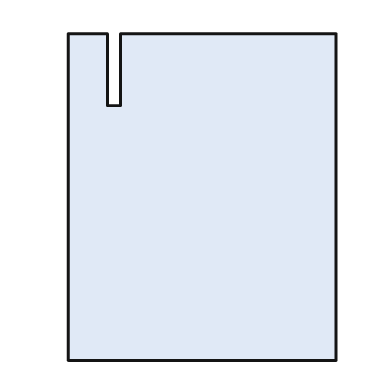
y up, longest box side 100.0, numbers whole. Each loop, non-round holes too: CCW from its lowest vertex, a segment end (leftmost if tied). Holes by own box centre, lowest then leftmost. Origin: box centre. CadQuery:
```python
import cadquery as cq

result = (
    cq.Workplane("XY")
    .moveTo(-41.0, -50.0)
    .lineTo(41.0, -50.0)
    .lineTo(41.0, 50.0)
    .lineTo(-25.0, 50.0)
    .lineTo(-25.0, 28.0)
    .lineTo(-29.0, 28.0)
    .lineTo(-29.0, 50.0)
    .lineTo(-41.0, 50.0)
    .close()
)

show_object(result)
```